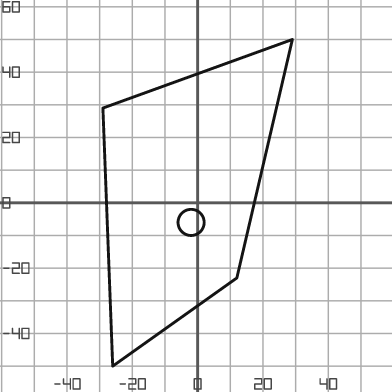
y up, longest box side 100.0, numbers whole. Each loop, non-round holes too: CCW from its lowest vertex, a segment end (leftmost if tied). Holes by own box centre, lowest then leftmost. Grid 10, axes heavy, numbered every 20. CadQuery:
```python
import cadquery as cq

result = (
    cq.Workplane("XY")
    .moveTo(-26.0, -50.0)
    .lineTo(12.0, -23.0)
    .lineTo(29.0, 50.0)
    .lineTo(-29.0, 29.0)
    .close()
    .moveTo(-2.0, -6.0)
    .circle(4.0)
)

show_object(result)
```